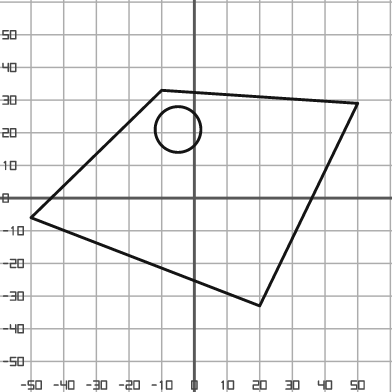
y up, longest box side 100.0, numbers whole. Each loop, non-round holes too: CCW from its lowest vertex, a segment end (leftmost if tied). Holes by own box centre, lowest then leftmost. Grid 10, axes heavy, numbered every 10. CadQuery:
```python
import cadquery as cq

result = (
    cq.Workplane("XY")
    .moveTo(20.0, -33.0)
    .lineTo(50.0, 29.0)
    .lineTo(-10.0, 33.0)
    .lineTo(-50.0, -6.0)
    .close()
    .moveTo(-5.0, 21.0)
    .circle(7.0)
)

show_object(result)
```